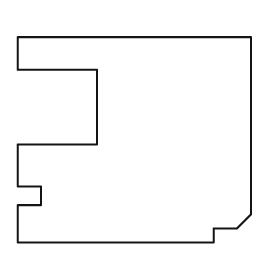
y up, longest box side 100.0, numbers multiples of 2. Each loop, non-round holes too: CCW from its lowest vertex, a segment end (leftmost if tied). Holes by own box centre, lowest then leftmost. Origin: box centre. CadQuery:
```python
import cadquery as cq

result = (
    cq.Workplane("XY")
    .moveTo(-50.0, -44.0)
    .lineTo(34.0, -44.0)
    .lineTo(34.0, -38.0)
    .lineTo(44.0, -38.0)
    .lineTo(50.0, -32.0)
    .lineTo(50.0, 44.0)
    .lineTo(-50.0, 44.0)
    .lineTo(-50.0, 30.0)
    .lineTo(-16.0, 30.0)
    .lineTo(-16.0, -2.0)
    .lineTo(-50.0, -2.0)
    .lineTo(-50.0, -20.0)
    .lineTo(-40.0, -20.0)
    .lineTo(-40.0, -28.0)
    .lineTo(-50.0, -28.0)
    .close()
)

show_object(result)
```